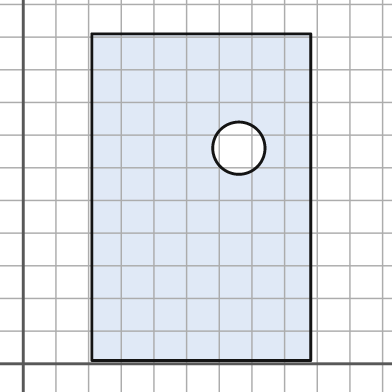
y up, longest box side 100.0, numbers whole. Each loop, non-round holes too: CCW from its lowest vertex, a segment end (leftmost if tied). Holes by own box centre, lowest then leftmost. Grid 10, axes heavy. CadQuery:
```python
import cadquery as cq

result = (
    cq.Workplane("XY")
    .moveTo(21.0, 1.0)
    .lineTo(88.0, 1.0)
    .lineTo(88.0, 101.0)
    .lineTo(21.0, 101.0)
    .close()
    .moveTo(66.0, 66.0)
    .circle(8.0)
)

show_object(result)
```